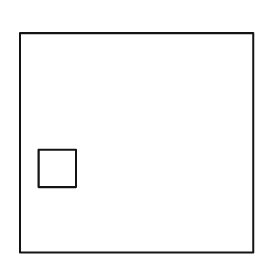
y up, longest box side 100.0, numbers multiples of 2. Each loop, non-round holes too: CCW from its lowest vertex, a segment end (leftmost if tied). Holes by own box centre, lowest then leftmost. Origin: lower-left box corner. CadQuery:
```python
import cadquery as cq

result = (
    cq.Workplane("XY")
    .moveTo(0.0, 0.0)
    .lineTo(100.0, 0.0)
    .lineTo(100.0, 94.0)
    .lineTo(0.0, 94.0)
    .close()
    .moveTo(8.0, 28.0)
    .lineTo(24.0, 28.0)
    .lineTo(24.0, 44.0)
    .lineTo(8.0, 44.0)
    .close()
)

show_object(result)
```